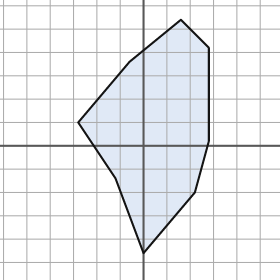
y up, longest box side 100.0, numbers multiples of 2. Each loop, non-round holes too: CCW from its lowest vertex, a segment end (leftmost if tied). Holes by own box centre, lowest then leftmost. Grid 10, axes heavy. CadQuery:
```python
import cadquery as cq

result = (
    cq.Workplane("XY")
    .moveTo(0.0, -46.0)
    .lineTo(22.0, -20.0)
    .lineTo(28.0, 2.0)
    .lineTo(28.0, 42.0)
    .lineTo(16.0, 54.0)
    .lineTo(-6.0, 36.0)
    .lineTo(-28.0, 10.0)
    .lineTo(-12.0, -14.0)
    .close()
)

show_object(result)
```